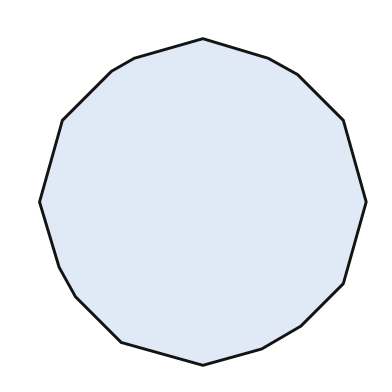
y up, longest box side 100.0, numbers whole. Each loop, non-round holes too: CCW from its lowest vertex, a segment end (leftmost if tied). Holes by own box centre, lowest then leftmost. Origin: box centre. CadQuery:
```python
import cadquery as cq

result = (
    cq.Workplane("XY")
    .moveTo(0.0, -50.0)
    .lineTo(18.0, -45.0)
    .lineTo(30.0, -38.0)
    .lineTo(43.0, -25.0)
    .lineTo(50.0, 0.0)
    .lineTo(43.0, 25.0)
    .lineTo(29.0, 39.0)
    .lineTo(20.0, 44.0)
    .lineTo(0.0, 50.0)
    .lineTo(-21.0, 44.0)
    .lineTo(-28.0, 40.0)
    .lineTo(-43.0, 25.0)
    .lineTo(-50.0, 0.0)
    .lineTo(-44.0, -20.0)
    .lineTo(-39.0, -29.0)
    .lineTo(-25.0, -43.0)
    .close()
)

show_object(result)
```